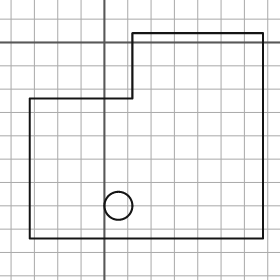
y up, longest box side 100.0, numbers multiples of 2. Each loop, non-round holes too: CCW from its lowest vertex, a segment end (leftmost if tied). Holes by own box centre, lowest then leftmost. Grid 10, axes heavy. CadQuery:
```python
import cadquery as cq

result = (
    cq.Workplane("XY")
    .moveTo(-32.0, -84.0)
    .lineTo(68.0, -84.0)
    .lineTo(68.0, 4.0)
    .lineTo(12.0, 4.0)
    .lineTo(12.0, -24.0)
    .lineTo(-32.0, -24.0)
    .close()
    .moveTo(6.0, -70.0)
    .circle(6.0)
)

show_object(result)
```